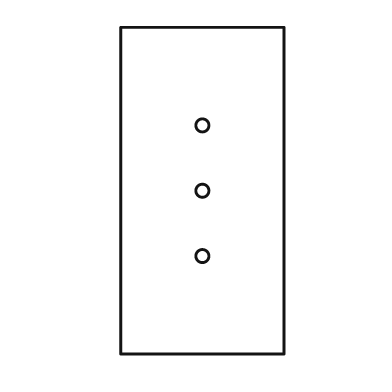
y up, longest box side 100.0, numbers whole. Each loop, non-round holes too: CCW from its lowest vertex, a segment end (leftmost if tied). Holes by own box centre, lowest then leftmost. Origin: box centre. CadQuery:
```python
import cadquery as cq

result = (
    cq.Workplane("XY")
    .moveTo(-25.0, -50.0)
    .lineTo(25.0, -50.0)
    .lineTo(25.0, 50.0)
    .lineTo(-25.0, 50.0)
    .close()
    .moveTo(0.0, -20.0)
    .circle(2.0)
    .moveTo(0.0, 0.0)
    .circle(2.0)
    .moveTo(0.0, 20.0)
    .circle(2.0)
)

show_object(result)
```